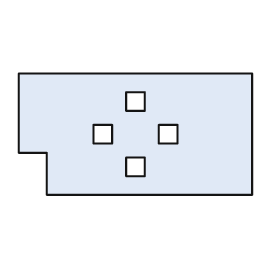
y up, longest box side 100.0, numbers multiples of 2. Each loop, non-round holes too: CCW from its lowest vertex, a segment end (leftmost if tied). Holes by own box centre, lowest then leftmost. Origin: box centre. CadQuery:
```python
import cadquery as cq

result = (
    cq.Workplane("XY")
    .moveTo(-38.0, -26.0)
    .lineTo(50.0, -26.0)
    .lineTo(50.0, 26.0)
    .lineTo(-50.0, 26.0)
    .lineTo(-50.0, -8.0)
    .lineTo(-38.0, -8.0)
    .close()
    .moveTo(-4.0, -18.0)
    .lineTo(4.0, -18.0)
    .lineTo(4.0, -10.0)
    .lineTo(-4.0, -10.0)
    .close()
    .moveTo(-18.0, -4.0)
    .lineTo(-10.0, -4.0)
    .lineTo(-10.0, 4.0)
    .lineTo(-18.0, 4.0)
    .close()
    .moveTo(10.0, -4.0)
    .lineTo(18.0, -4.0)
    .lineTo(18.0, 4.0)
    .lineTo(10.0, 4.0)
    .close()
    .moveTo(-4.0, 10.0)
    .lineTo(4.0, 10.0)
    .lineTo(4.0, 18.0)
    .lineTo(-4.0, 18.0)
    .close()
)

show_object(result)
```